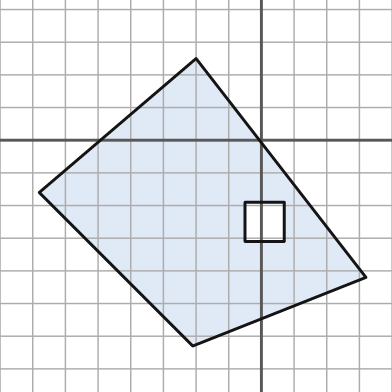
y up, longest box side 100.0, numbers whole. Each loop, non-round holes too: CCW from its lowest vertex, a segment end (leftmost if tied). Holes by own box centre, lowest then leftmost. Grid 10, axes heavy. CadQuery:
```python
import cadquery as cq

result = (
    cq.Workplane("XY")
    .moveTo(-21.0, -63.0)
    .lineTo(32.0, -42.0)
    .lineTo(-20.0, 25.0)
    .lineTo(-68.0, -16.0)
    .close()
    .moveTo(-5.0, -31.0)
    .lineTo(7.0, -31.0)
    .lineTo(7.0, -19.0)
    .lineTo(-5.0, -19.0)
    .close()
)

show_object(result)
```